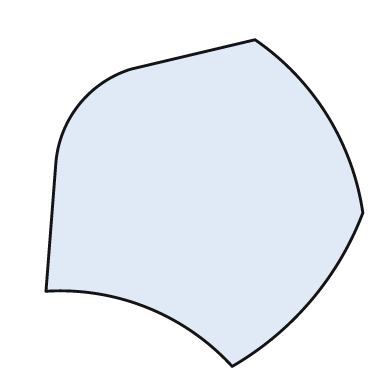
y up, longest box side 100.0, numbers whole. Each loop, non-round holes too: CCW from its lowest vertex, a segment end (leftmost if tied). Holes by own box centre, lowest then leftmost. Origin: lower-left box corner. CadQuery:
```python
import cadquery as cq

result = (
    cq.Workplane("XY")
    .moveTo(57.0, 0.0)
    .threePointArc((81.0, 20.0), (97.0, 47.0))
    .threePointArc((86.0, 77.0), (64.0, 100.0))
    .lineTo(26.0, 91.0)
    .threePointArc((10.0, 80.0), (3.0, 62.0))
    .lineTo(0.0, 23.0)
    .threePointArc((31.0, 18.0), (57.0, 0.0))
    .close()
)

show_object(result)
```